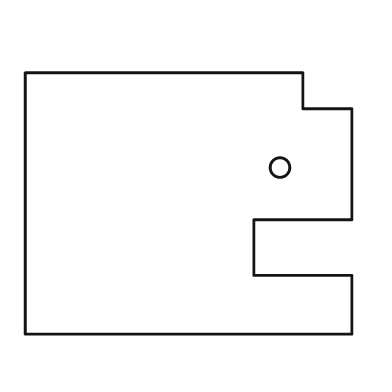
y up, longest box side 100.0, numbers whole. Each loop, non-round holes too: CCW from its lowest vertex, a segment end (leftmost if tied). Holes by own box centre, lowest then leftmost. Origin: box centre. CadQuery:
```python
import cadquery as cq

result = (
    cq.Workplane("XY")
    .moveTo(-50.0, -40.0)
    .lineTo(50.0, -40.0)
    .lineTo(50.0, -22.0)
    .lineTo(20.0, -22.0)
    .lineTo(20.0, -5.0)
    .lineTo(50.0, -5.0)
    .lineTo(50.0, 29.0)
    .lineTo(35.0, 29.0)
    .lineTo(35.0, 40.0)
    .lineTo(-50.0, 40.0)
    .close()
    .moveTo(28.0, 11.0)
    .circle(3.0)
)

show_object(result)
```